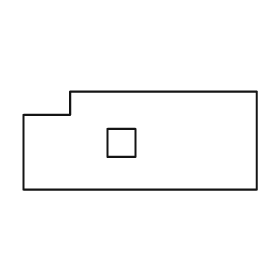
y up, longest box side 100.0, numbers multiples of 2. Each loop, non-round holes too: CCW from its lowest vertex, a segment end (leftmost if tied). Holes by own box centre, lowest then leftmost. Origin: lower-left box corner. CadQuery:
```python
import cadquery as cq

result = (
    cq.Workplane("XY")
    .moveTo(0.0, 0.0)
    .lineTo(100.0, 0.0)
    .lineTo(100.0, 42.0)
    .lineTo(20.0, 42.0)
    .lineTo(20.0, 32.0)
    .lineTo(0.0, 32.0)
    .close()
    .moveTo(36.0, 14.0)
    .lineTo(48.0, 14.0)
    .lineTo(48.0, 26.0)
    .lineTo(36.0, 26.0)
    .close()
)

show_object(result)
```